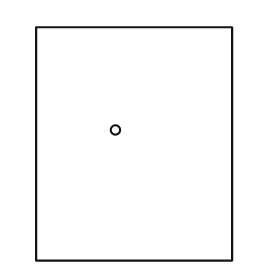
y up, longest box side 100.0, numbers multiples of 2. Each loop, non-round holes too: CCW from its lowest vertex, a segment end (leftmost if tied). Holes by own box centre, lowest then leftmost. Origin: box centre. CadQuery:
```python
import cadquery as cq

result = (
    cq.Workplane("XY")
    .moveTo(-42.0, -50.0)
    .lineTo(42.0, -50.0)
    .lineTo(42.0, 50.0)
    .lineTo(-42.0, 50.0)
    .close()
    .moveTo(-8.0, 6.0)
    .circle(2.0)
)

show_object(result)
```